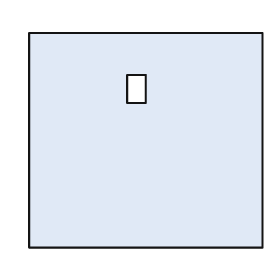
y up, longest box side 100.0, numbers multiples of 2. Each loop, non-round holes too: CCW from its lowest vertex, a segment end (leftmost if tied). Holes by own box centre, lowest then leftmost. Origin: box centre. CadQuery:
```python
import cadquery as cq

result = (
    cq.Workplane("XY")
    .moveTo(-50.0, -46.0)
    .lineTo(50.0, -46.0)
    .lineTo(50.0, 46.0)
    .lineTo(-50.0, 46.0)
    .close()
    .moveTo(-8.0, 16.0)
    .lineTo(0.0, 16.0)
    .lineTo(0.0, 28.0)
    .lineTo(-8.0, 28.0)
    .close()
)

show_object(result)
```